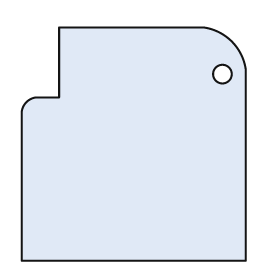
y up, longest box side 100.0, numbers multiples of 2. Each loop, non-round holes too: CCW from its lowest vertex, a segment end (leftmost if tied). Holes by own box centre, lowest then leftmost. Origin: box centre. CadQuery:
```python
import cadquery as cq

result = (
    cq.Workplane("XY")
    .moveTo(-48.0, -50.0)
    .lineTo(48.0, -50.0)
    .lineTo(48.0, 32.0)
    .threePointArc((42.0, 44.0), (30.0, 50.0))
    .lineTo(-32.0, 50.0)
    .lineTo(-32.0, 20.0)
    .lineTo(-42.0, 20.0)
    .threePointArc((-46.0, 18.0), (-48.0, 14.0))
    .close()
    .moveTo(38.0, 30.0)
    .circle(4.0)
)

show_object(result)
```